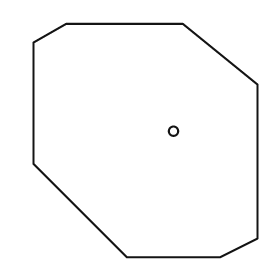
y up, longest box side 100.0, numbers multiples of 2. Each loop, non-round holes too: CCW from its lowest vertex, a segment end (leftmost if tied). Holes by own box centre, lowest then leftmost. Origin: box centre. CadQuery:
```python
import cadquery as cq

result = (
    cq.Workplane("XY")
    .moveTo(-8.0, -50.0)
    .lineTo(32.0, -50.0)
    .lineTo(48.0, -42.0)
    .lineTo(48.0, 24.0)
    .lineTo(16.0, 50.0)
    .lineTo(-34.0, 50.0)
    .lineTo(-48.0, 42.0)
    .lineTo(-48.0, -10.0)
    .close()
    .moveTo(12.0, 4.0)
    .circle(2.0)
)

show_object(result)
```